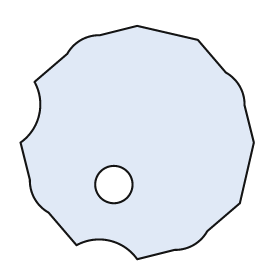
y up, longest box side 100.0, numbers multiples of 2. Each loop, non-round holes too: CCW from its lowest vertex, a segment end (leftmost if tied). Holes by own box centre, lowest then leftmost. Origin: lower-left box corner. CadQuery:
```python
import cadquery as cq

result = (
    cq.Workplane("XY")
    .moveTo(50.0, 0.0)
    .lineTo(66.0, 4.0)
    .threePointArc((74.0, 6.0), (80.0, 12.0))
    .lineTo(94.0, 24.0)
    .lineTo(100.0, 50.0)
    .lineTo(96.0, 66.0)
    .threePointArc((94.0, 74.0), (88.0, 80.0))
    .lineTo(76.0, 94.0)
    .lineTo(50.0, 100.0)
    .lineTo(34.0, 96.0)
    .threePointArc((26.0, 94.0), (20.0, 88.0))
    .lineTo(6.0, 76.0)
    .threePointArc((8.0, 62.0), (0.0, 50.0))
    .lineTo(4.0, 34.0)
    .threePointArc((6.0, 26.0), (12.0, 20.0))
    .lineTo(24.0, 6.0)
    .threePointArc((38.0, 8.0), (50.0, 0.0))
    .close()
    .moveTo(40.0, 32.0)
    .circle(8.0)
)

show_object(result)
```